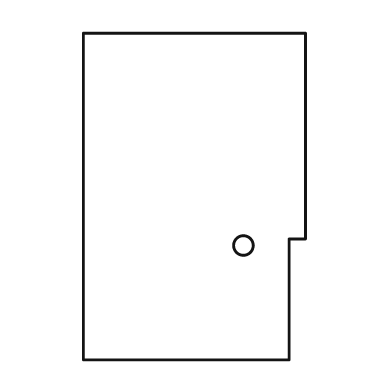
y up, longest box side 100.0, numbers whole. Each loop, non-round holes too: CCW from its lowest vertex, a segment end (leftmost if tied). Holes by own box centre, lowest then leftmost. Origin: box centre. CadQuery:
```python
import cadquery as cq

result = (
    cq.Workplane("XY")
    .moveTo(-34.0, -50.0)
    .lineTo(29.0, -50.0)
    .lineTo(29.0, -13.0)
    .lineTo(34.0, -13.0)
    .lineTo(34.0, 50.0)
    .lineTo(-34.0, 50.0)
    .close()
    .moveTo(15.0, -15.0)
    .circle(3.0)
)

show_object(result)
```